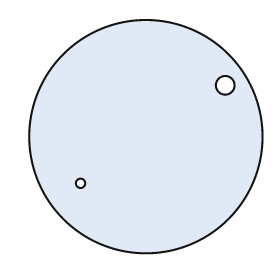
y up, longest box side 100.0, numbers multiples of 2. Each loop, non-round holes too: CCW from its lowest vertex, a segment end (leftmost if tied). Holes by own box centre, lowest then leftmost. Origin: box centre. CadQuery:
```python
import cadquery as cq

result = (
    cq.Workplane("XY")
    .moveTo(0.0, 0.0)
    .circle(50.0)
    .moveTo(-28.0, -20.0)
    .circle(2.0)
    .moveTo(34.0, 22.0)
    .circle(4.0)
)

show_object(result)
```